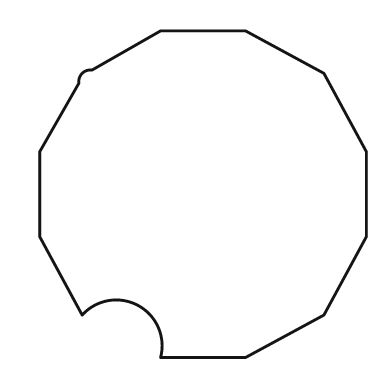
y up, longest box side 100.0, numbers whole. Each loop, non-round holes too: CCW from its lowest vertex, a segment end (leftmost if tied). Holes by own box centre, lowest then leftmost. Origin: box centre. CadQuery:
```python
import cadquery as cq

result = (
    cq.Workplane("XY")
    .moveTo(-13.0, -50.0)
    .lineTo(13.0, -50.0)
    .lineTo(37.0, -37.0)
    .lineTo(50.0, -13.0)
    .lineTo(50.0, 13.0)
    .lineTo(37.0, 37.0)
    .lineTo(13.0, 50.0)
    .lineTo(-13.0, 50.0)
    .lineTo(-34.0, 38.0)
    .threePointArc((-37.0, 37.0), (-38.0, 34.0))
    .lineTo(-50.0, 13.0)
    .lineTo(-50.0, -13.0)
    .lineTo(-37.0, -37.0)
    .threePointArc((-20.0, -34.0), (-13.0, -50.0))
    .close()
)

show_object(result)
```